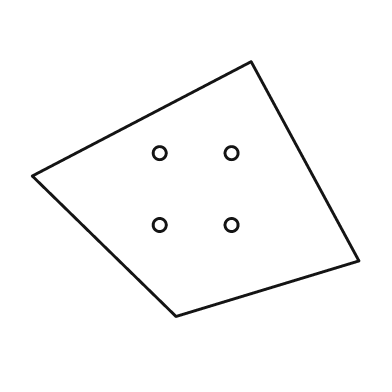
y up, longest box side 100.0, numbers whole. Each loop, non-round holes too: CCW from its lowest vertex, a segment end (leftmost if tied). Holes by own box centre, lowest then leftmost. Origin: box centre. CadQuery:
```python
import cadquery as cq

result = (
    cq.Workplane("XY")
    .moveTo(-6.0, -39.0)
    .lineTo(50.0, -22.0)
    .lineTo(17.0, 39.0)
    .lineTo(-50.0, 4.0)
    .close()
    .moveTo(-11.0, -11.0)
    .circle(2.0)
    .moveTo(11.0, -11.0)
    .circle(2.0)
    .moveTo(-11.0, 11.0)
    .circle(2.0)
    .moveTo(11.0, 11.0)
    .circle(2.0)
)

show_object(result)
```